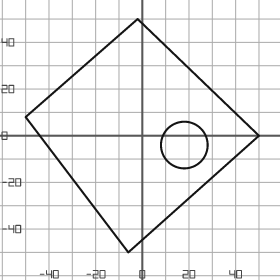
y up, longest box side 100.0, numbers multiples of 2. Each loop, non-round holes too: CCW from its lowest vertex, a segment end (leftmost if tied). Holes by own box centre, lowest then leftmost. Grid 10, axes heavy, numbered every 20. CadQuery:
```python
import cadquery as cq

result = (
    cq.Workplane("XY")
    .moveTo(-6.0, -50.0)
    .lineTo(50.0, 0.0)
    .lineTo(-2.0, 50.0)
    .lineTo(-50.0, 8.0)
    .close()
    .moveTo(18.0, -4.0)
    .circle(10.0)
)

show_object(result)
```